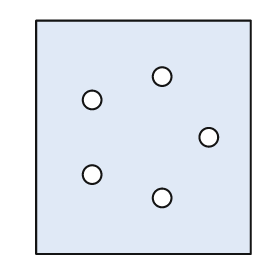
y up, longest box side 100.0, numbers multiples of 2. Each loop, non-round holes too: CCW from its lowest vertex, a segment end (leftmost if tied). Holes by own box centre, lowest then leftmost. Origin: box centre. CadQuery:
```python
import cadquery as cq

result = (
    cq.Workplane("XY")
    .moveTo(-46.0, -50.0)
    .lineTo(46.0, -50.0)
    .lineTo(46.0, 50.0)
    .lineTo(-46.0, 50.0)
    .close()
    .moveTo(8.0, -26.0)
    .circle(4.0)
    .moveTo(-22.0, -16.0)
    .circle(4.0)
    .moveTo(28.0, 0.0)
    .circle(4.0)
    .moveTo(-22.0, 16.0)
    .circle(4.0)
    .moveTo(8.0, 26.0)
    .circle(4.0)
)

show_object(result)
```